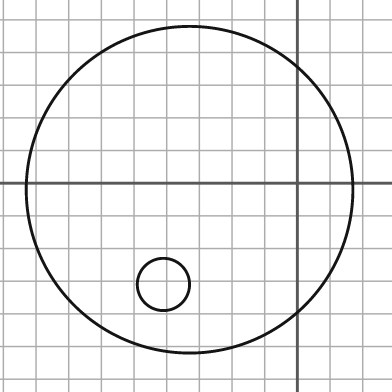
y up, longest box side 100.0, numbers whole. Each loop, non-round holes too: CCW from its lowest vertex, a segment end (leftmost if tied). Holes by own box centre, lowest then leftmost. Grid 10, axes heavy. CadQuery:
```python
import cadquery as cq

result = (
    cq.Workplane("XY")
    .moveTo(-33.0, -2.0)
    .circle(50.0)
    .moveTo(-41.0, -31.0)
    .circle(8.0)
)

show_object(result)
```